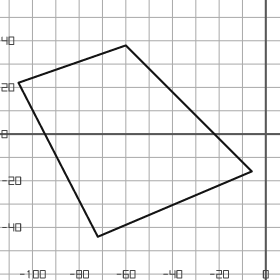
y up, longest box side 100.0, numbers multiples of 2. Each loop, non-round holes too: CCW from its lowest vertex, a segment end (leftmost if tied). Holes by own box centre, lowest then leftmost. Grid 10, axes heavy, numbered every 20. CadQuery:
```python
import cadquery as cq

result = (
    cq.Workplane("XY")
    .moveTo(-72.0, -44.0)
    .lineTo(-6.0, -16.0)
    .lineTo(-60.0, 38.0)
    .lineTo(-106.0, 22.0)
    .close()
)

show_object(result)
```